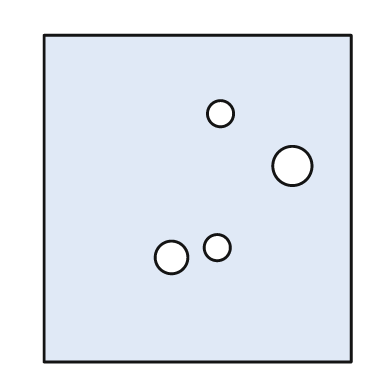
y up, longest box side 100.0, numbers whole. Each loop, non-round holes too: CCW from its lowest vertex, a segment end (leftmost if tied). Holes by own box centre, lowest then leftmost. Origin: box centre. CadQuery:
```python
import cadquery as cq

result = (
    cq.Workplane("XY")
    .moveTo(-47.0, -50.0)
    .lineTo(47.0, -50.0)
    .lineTo(47.0, 50.0)
    .lineTo(-47.0, 50.0)
    .close()
    .moveTo(-8.0, -18.0)
    .circle(5.0)
    .moveTo(6.0, -15.0)
    .circle(4.0)
    .moveTo(29.0, 10.0)
    .circle(6.0)
    .moveTo(7.0, 26.0)
    .circle(4.0)
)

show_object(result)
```